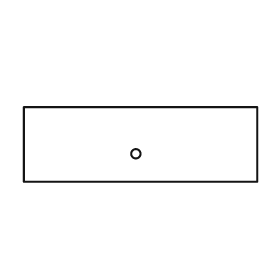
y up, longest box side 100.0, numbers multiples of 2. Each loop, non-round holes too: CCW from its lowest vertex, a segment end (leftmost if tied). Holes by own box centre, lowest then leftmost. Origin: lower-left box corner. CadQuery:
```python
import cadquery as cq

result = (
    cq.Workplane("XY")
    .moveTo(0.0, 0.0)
    .lineTo(100.0, 0.0)
    .lineTo(100.0, 32.0)
    .lineTo(0.0, 32.0)
    .close()
    .moveTo(48.0, 12.0)
    .circle(2.0)
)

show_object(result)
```